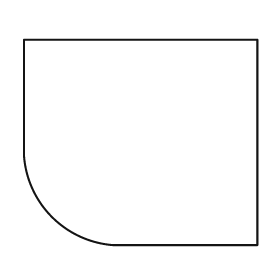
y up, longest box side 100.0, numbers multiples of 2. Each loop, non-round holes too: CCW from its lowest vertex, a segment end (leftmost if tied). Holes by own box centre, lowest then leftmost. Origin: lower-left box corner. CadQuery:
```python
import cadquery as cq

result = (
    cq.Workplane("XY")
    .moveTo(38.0, 0.0)
    .lineTo(100.0, 0.0)
    .lineTo(100.0, 88.0)
    .lineTo(0.0, 88.0)
    .lineTo(0.0, 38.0)
    .threePointArc((12.0, 12.0), (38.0, 0.0))
    .close()
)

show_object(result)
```